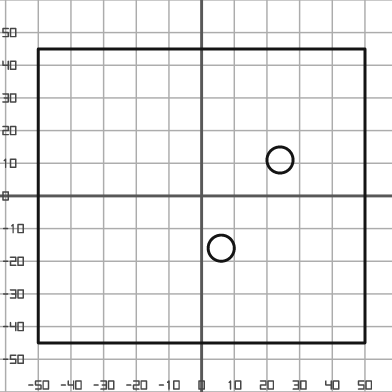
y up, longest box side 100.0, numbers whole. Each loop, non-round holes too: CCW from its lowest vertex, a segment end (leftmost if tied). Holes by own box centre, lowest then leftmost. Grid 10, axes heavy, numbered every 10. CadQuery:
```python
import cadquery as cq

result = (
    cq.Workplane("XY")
    .moveTo(-50.0, -45.0)
    .lineTo(50.0, -45.0)
    .lineTo(50.0, 45.0)
    .lineTo(-50.0, 45.0)
    .close()
    .moveTo(6.0, -16.0)
    .circle(4.0)
    .moveTo(24.0, 11.0)
    .circle(4.0)
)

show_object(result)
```